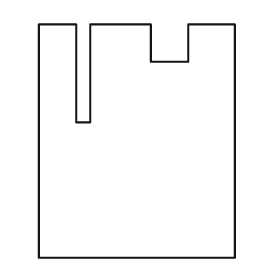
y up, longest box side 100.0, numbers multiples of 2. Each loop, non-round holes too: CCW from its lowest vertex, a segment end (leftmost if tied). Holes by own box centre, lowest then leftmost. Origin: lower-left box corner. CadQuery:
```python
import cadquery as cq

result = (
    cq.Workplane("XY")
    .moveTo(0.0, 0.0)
    .lineTo(84.0, 0.0)
    .lineTo(84.0, 100.0)
    .lineTo(64.0, 100.0)
    .lineTo(64.0, 84.0)
    .lineTo(48.0, 84.0)
    .lineTo(48.0, 100.0)
    .lineTo(22.0, 100.0)
    .lineTo(22.0, 58.0)
    .lineTo(16.0, 58.0)
    .lineTo(16.0, 100.0)
    .lineTo(0.0, 100.0)
    .close()
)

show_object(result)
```